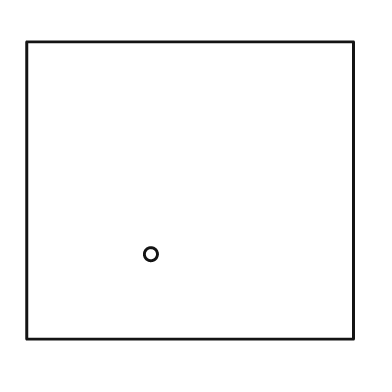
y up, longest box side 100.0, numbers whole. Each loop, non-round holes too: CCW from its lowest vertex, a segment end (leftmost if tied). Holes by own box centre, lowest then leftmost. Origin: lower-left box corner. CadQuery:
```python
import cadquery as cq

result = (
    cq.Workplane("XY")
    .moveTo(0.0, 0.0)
    .lineTo(100.0, 0.0)
    .lineTo(100.0, 91.0)
    .lineTo(0.0, 91.0)
    .close()
    .moveTo(38.0, 26.0)
    .circle(2.0)
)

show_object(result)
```